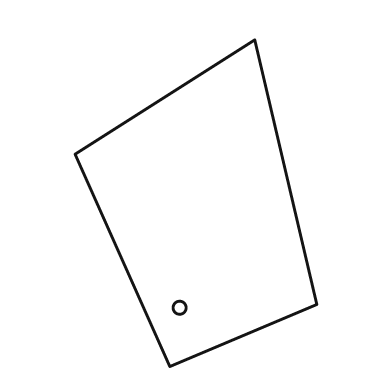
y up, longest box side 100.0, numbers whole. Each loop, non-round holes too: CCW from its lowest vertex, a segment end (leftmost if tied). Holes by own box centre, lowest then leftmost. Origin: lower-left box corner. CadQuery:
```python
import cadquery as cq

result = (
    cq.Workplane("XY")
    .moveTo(29.0, 0.0)
    .lineTo(74.0, 19.0)
    .lineTo(55.0, 100.0)
    .lineTo(0.0, 65.0)
    .close()
    .moveTo(32.0, 18.0)
    .circle(2.0)
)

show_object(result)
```